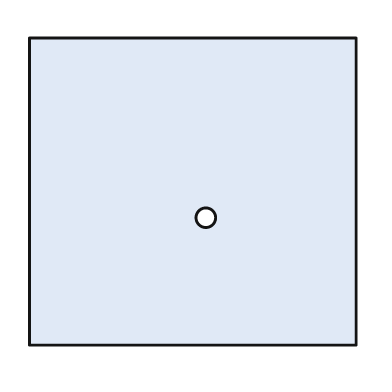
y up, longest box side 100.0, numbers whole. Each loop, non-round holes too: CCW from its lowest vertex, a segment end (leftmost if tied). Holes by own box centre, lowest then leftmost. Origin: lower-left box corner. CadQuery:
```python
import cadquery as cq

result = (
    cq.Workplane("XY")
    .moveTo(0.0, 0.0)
    .lineTo(100.0, 0.0)
    .lineTo(100.0, 94.0)
    .lineTo(0.0, 94.0)
    .close()
    .moveTo(54.0, 39.0)
    .circle(3.0)
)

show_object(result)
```